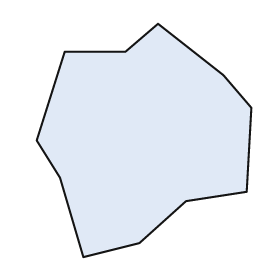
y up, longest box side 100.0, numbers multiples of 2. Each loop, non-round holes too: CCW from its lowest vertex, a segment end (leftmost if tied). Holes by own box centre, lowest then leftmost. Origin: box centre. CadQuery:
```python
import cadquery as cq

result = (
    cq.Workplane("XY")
    .moveTo(-26.0, -50.0)
    .lineTo(-2.0, -44.0)
    .lineTo(18.0, -26.0)
    .lineTo(44.0, -22.0)
    .lineTo(46.0, 14.0)
    .lineTo(34.0, 28.0)
    .lineTo(6.0, 50.0)
    .lineTo(-8.0, 38.0)
    .lineTo(-34.0, 38.0)
    .lineTo(-46.0, 0.0)
    .lineTo(-36.0, -16.0)
    .close()
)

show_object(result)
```